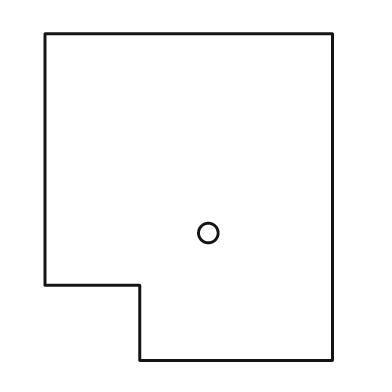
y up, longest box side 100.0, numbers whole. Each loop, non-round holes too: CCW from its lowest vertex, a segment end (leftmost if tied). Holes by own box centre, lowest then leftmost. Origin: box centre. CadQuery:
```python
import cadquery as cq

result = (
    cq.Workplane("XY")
    .moveTo(-15.0, -50.0)
    .lineTo(44.0, -50.0)
    .lineTo(44.0, 50.0)
    .lineTo(-44.0, 50.0)
    .lineTo(-44.0, -27.0)
    .lineTo(-15.0, -27.0)
    .close()
    .moveTo(6.0, -11.0)
    .circle(3.0)
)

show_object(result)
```